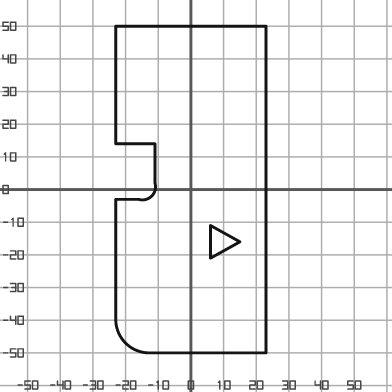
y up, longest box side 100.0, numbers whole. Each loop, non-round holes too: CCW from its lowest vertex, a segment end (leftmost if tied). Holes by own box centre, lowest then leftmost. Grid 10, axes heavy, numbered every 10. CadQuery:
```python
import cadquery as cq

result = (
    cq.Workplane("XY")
    .moveTo(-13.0, -50.0)
    .lineTo(23.0, -50.0)
    .lineTo(23.0, 50.0)
    .lineTo(-23.0, 50.0)
    .lineTo(-23.0, 14.0)
    .lineTo(-11.0, 14.0)
    .lineTo(-11.0, 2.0)
    .threePointArc((-12.0, -2.0), (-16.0, -3.0))
    .lineTo(-23.0, -3.0)
    .lineTo(-23.0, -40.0)
    .threePointArc((-20.0, -47.0), (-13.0, -50.0))
    .close()
    .moveTo(6.0, -21.0)
    .lineTo(15.0, -16.0)
    .lineTo(6.0, -11.0)
    .close()
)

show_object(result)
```